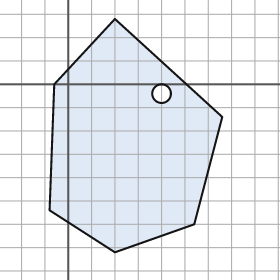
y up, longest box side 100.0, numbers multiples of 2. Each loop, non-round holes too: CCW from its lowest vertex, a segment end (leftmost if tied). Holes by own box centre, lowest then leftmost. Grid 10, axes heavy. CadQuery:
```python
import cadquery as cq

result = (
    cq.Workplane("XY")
    .moveTo(20.0, -72.0)
    .lineTo(54.0, -60.0)
    .lineTo(66.0, -14.0)
    .lineTo(20.0, 28.0)
    .lineTo(-6.0, 0.0)
    .lineTo(-8.0, -54.0)
    .close()
    .moveTo(40.0, -4.0)
    .circle(4.0)
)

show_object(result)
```